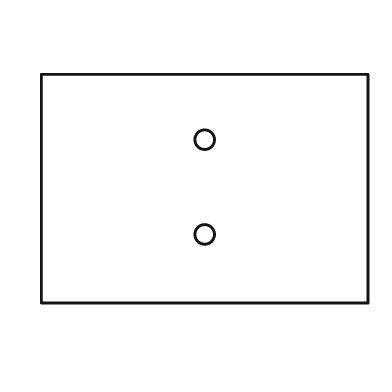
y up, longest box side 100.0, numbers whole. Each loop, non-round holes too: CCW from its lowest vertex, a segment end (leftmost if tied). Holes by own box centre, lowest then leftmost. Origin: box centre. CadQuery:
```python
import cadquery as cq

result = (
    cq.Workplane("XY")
    .moveTo(-50.0, -35.0)
    .lineTo(50.0, -35.0)
    .lineTo(50.0, 35.0)
    .lineTo(-50.0, 35.0)
    .close()
    .moveTo(0.0, -14.0)
    .circle(3.0)
    .moveTo(0.0, 15.0)
    .circle(3.0)
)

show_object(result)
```